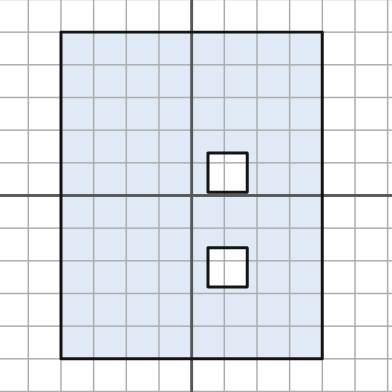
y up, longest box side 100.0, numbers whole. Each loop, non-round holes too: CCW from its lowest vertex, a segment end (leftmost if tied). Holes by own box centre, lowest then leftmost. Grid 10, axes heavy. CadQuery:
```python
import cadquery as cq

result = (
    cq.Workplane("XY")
    .moveTo(-40.0, -50.0)
    .lineTo(40.0, -50.0)
    .lineTo(40.0, 50.0)
    .lineTo(-40.0, 50.0)
    .close()
    .moveTo(5.0, -28.0)
    .lineTo(17.0, -28.0)
    .lineTo(17.0, -16.0)
    .lineTo(5.0, -16.0)
    .close()
    .moveTo(5.0, 1.0)
    .lineTo(17.0, 1.0)
    .lineTo(17.0, 13.0)
    .lineTo(5.0, 13.0)
    .close()
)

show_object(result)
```